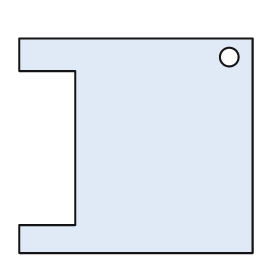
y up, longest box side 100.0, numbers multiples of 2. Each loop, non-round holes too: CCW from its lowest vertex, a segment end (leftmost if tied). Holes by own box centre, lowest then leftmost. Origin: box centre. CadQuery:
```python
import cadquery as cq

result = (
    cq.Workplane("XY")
    .moveTo(-50.0, -46.0)
    .lineTo(50.0, -46.0)
    .lineTo(50.0, 46.0)
    .lineTo(-50.0, 46.0)
    .lineTo(-50.0, 32.0)
    .lineTo(-26.0, 32.0)
    .lineTo(-26.0, -34.0)
    .lineTo(-50.0, -34.0)
    .close()
    .moveTo(40.0, 38.0)
    .circle(4.0)
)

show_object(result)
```